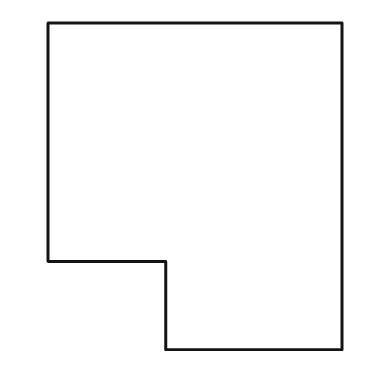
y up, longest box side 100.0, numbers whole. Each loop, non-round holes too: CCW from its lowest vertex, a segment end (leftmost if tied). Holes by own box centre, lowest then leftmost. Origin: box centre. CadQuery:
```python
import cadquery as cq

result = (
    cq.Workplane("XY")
    .moveTo(-9.0, -50.0)
    .lineTo(45.0, -50.0)
    .lineTo(45.0, 50.0)
    .lineTo(-45.0, 50.0)
    .lineTo(-45.0, -23.0)
    .lineTo(-9.0, -23.0)
    .close()
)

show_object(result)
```